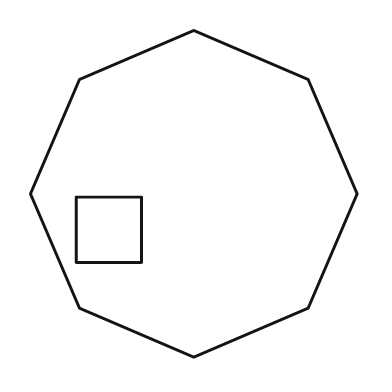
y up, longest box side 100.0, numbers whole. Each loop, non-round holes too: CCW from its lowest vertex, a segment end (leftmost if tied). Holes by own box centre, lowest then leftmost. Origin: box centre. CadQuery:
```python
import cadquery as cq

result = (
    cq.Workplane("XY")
    .moveTo(0.0, -50.0)
    .lineTo(35.0, -35.0)
    .lineTo(50.0, 0.0)
    .lineTo(35.0, 35.0)
    .lineTo(0.0, 50.0)
    .lineTo(-35.0, 35.0)
    .lineTo(-50.0, 0.0)
    .lineTo(-35.0, -35.0)
    .close()
    .moveTo(-36.0, -21.0)
    .lineTo(-16.0, -21.0)
    .lineTo(-16.0, -1.0)
    .lineTo(-36.0, -1.0)
    .close()
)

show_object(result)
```